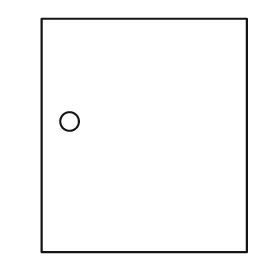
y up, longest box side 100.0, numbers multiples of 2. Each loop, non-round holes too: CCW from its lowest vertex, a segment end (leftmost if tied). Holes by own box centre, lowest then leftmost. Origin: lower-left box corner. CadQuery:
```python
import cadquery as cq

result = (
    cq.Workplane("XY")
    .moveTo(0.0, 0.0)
    .lineTo(88.0, 0.0)
    .lineTo(88.0, 100.0)
    .lineTo(0.0, 100.0)
    .close()
    .moveTo(12.0, 56.0)
    .circle(4.0)
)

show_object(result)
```